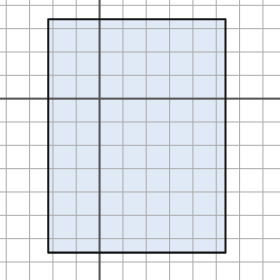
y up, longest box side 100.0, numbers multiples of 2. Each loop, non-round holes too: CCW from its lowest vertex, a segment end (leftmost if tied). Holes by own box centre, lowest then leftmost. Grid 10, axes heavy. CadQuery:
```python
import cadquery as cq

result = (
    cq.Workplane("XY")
    .moveTo(-22.0, -66.0)
    .lineTo(54.0, -66.0)
    .lineTo(54.0, 34.0)
    .lineTo(-22.0, 34.0)
    .close()
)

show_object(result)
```